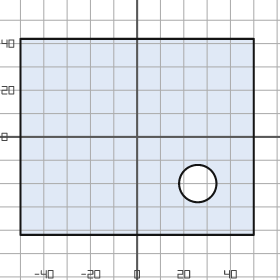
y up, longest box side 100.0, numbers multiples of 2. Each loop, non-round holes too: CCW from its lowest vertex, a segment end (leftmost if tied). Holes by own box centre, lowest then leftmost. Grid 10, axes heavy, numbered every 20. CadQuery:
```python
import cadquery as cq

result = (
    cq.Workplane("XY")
    .moveTo(-50.0, -42.0)
    .lineTo(50.0, -42.0)
    .lineTo(50.0, 42.0)
    .lineTo(-50.0, 42.0)
    .close()
    .moveTo(26.0, -20.0)
    .circle(8.0)
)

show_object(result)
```